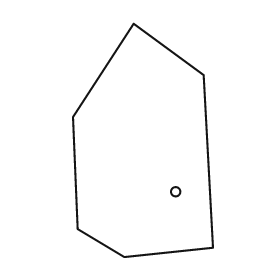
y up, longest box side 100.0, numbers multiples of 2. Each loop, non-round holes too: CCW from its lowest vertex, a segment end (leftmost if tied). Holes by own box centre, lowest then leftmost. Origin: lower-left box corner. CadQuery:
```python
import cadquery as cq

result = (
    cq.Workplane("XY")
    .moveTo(22.0, 0.0)
    .lineTo(60.0, 4.0)
    .lineTo(56.0, 78.0)
    .lineTo(26.0, 100.0)
    .lineTo(0.0, 60.0)
    .lineTo(2.0, 12.0)
    .close()
    .moveTo(44.0, 28.0)
    .circle(2.0)
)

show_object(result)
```